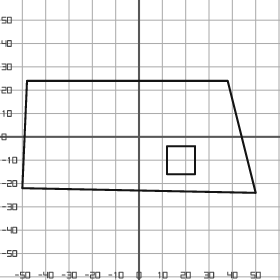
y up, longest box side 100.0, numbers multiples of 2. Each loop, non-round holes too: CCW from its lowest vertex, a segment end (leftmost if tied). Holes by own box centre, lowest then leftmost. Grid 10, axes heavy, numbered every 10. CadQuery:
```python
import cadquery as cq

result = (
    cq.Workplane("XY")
    .moveTo(50.0, -24.0)
    .lineTo(38.0, 24.0)
    .lineTo(-48.0, 24.0)
    .lineTo(-50.0, -22.0)
    .close()
    .moveTo(12.0, -16.0)
    .lineTo(24.0, -16.0)
    .lineTo(24.0, -4.0)
    .lineTo(12.0, -4.0)
    .close()
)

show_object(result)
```